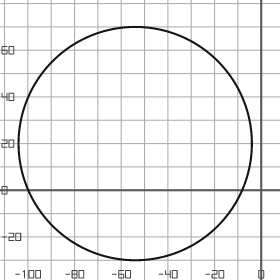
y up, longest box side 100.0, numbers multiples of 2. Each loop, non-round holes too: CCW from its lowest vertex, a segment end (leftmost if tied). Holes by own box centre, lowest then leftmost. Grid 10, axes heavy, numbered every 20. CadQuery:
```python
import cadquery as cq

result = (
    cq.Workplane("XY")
    .moveTo(-54.0, 20.0)
    .circle(50.0)
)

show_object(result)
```